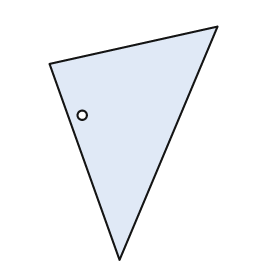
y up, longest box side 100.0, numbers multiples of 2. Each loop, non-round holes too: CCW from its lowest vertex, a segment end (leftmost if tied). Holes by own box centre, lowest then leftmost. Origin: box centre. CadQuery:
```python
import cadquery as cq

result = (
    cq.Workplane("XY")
    .moveTo(-6.0, -50.0)
    .lineTo(36.0, 50.0)
    .lineTo(-36.0, 34.0)
    .close()
    .moveTo(-22.0, 12.0)
    .circle(2.0)
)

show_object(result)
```